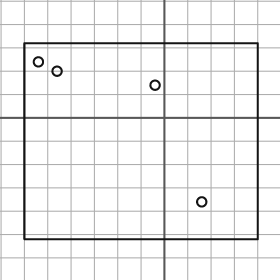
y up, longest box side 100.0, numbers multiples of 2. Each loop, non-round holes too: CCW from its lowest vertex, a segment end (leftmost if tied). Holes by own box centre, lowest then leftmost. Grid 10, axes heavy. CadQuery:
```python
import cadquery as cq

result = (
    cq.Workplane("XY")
    .moveTo(-60.0, -52.0)
    .lineTo(40.0, -52.0)
    .lineTo(40.0, 32.0)
    .lineTo(-60.0, 32.0)
    .close()
    .moveTo(16.0, -36.0)
    .circle(2.0)
    .moveTo(-4.0, 14.0)
    .circle(2.0)
    .moveTo(-46.0, 20.0)
    .circle(2.0)
    .moveTo(-54.0, 24.0)
    .circle(2.0)
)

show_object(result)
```